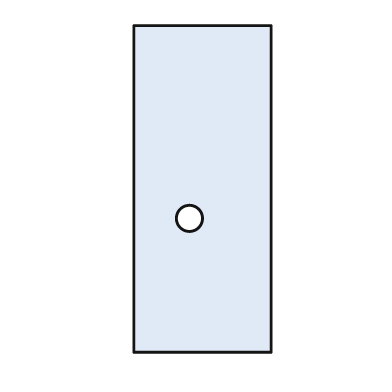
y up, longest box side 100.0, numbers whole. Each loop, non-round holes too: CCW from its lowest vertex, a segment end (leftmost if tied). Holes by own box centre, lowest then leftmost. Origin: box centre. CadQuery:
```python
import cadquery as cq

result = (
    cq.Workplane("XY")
    .moveTo(-21.0, -50.0)
    .lineTo(21.0, -50.0)
    .lineTo(21.0, 50.0)
    .lineTo(-21.0, 50.0)
    .close()
    .moveTo(-4.0, -9.0)
    .circle(4.0)
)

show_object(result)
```